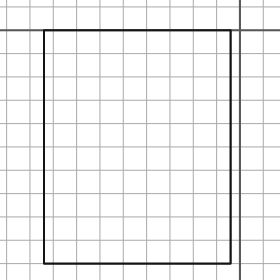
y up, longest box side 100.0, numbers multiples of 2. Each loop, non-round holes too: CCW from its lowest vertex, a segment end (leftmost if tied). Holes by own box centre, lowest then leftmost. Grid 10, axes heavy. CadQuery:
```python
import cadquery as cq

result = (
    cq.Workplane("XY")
    .moveTo(-84.0, -100.0)
    .lineTo(-4.0, -100.0)
    .lineTo(-4.0, 0.0)
    .lineTo(-84.0, 0.0)
    .close()
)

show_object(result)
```